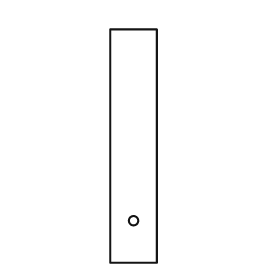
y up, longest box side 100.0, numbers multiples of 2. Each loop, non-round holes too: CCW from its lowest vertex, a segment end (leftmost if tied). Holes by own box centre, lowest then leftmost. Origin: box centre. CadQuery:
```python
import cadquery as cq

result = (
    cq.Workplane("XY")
    .moveTo(-10.0, -50.0)
    .lineTo(10.0, -50.0)
    .lineTo(10.0, 50.0)
    .lineTo(-10.0, 50.0)
    .close()
    .moveTo(0.0, -32.0)
    .circle(2.0)
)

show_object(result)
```